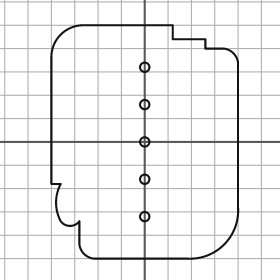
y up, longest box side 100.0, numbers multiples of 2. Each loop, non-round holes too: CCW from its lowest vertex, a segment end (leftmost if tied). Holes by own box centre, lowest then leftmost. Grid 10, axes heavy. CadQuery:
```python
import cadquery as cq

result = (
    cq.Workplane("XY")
    .moveTo(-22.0, -50.0)
    .lineTo(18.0, -50.0)
    .threePointArc((34.0, -44.0), (40.0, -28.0))
    .lineTo(40.0, 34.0)
    .threePointArc((38.0, 38.0), (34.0, 40.0))
    .lineTo(26.0, 40.0)
    .lineTo(26.0, 44.0)
    .lineTo(12.0, 44.0)
    .lineTo(12.0, 50.0)
    .lineTo(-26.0, 50.0)
    .threePointArc((-36.0, 46.0), (-40.0, 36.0))
    .lineTo(-40.0, -18.0)
    .lineTo(-36.0, -18.0)
    .threePointArc((-38.0, -26.0), (-36.0, -34.0))
    .threePointArc((-32.0, -36.0), (-28.0, -34.0))
    .lineTo(-28.0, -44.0)
    .threePointArc((-26.0, -48.0), (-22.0, -50.0))
    .close()
    .moveTo(0.0, -32.0)
    .circle(2.0)
    .moveTo(0.0, -16.0)
    .circle(2.0)
    .moveTo(0.0, 0.0)
    .circle(2.0)
    .moveTo(0.0, 16.0)
    .circle(2.0)
    .moveTo(0.0, 32.0)
    .circle(2.0)
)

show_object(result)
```